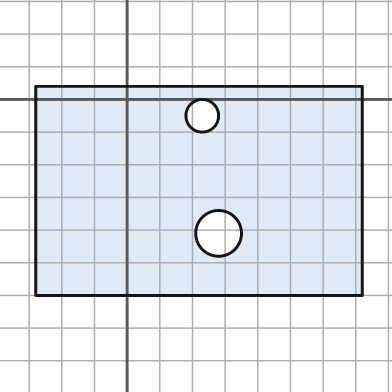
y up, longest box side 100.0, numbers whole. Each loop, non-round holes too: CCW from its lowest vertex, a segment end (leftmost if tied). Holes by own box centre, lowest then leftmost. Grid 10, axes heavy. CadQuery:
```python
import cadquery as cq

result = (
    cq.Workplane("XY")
    .moveTo(-28.0, -60.0)
    .lineTo(72.0, -60.0)
    .lineTo(72.0, 4.0)
    .lineTo(-28.0, 4.0)
    .close()
    .moveTo(28.0, -41.0)
    .circle(7.0)
    .moveTo(23.0, -5.0)
    .circle(5.0)
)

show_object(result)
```